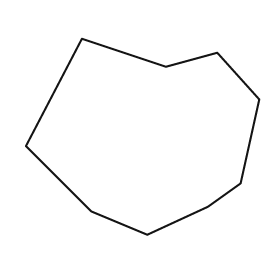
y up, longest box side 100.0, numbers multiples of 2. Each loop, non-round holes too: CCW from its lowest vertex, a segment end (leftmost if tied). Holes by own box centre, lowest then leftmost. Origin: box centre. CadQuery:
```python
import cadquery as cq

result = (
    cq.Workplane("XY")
    .moveTo(2.0, -42.0)
    .lineTo(28.0, -30.0)
    .lineTo(42.0, -20.0)
    .lineTo(50.0, 16.0)
    .lineTo(32.0, 36.0)
    .lineTo(10.0, 30.0)
    .lineTo(-26.0, 42.0)
    .lineTo(-50.0, -4.0)
    .lineTo(-22.0, -32.0)
    .close()
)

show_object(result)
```